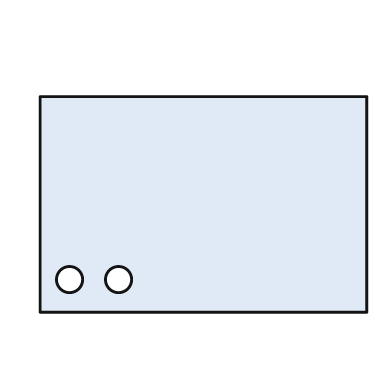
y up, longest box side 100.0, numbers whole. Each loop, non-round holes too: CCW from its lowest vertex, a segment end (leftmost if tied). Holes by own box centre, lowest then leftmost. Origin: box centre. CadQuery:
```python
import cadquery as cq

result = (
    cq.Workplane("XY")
    .moveTo(-50.0, -33.0)
    .lineTo(50.0, -33.0)
    .lineTo(50.0, 33.0)
    .lineTo(-50.0, 33.0)
    .close()
    .moveTo(-41.0, -23.0)
    .circle(4.0)
    .moveTo(-26.0, -23.0)
    .circle(4.0)
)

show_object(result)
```